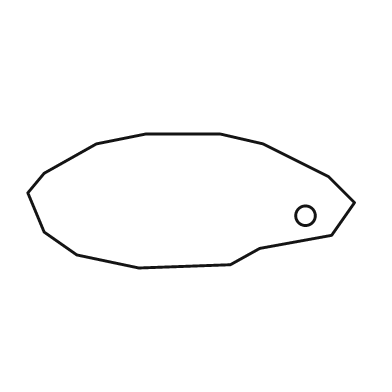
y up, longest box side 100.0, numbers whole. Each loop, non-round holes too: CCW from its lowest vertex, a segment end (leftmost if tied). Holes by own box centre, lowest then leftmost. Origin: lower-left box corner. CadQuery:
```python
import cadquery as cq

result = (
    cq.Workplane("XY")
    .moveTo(34.0, 0.0)
    .lineTo(62.0, 1.0)
    .lineTo(71.0, 6.0)
    .lineTo(93.0, 10.0)
    .lineTo(100.0, 20.0)
    .lineTo(92.0, 28.0)
    .lineTo(72.0, 38.0)
    .lineTo(59.0, 41.0)
    .lineTo(36.0, 41.0)
    .lineTo(21.0, 38.0)
    .lineTo(5.0, 29.0)
    .lineTo(0.0, 23.0)
    .lineTo(5.0, 11.0)
    .lineTo(15.0, 4.0)
    .close()
    .moveTo(85.0, 16.0)
    .circle(3.0)
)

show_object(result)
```